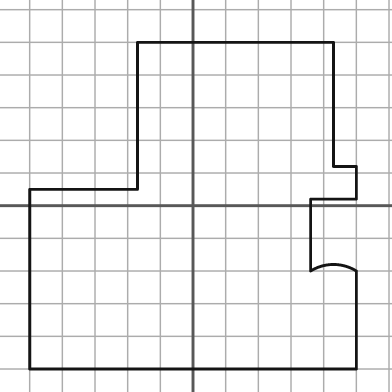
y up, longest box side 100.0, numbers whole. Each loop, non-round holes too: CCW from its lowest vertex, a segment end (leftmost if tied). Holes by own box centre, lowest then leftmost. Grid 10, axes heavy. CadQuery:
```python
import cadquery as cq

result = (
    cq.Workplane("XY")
    .moveTo(-50.0, -50.0)
    .lineTo(50.0, -50.0)
    .lineTo(50.0, -20.0)
    .threePointArc((43.0, -18.0), (36.0, -20.0))
    .lineTo(36.0, 2.0)
    .lineTo(50.0, 2.0)
    .lineTo(50.0, 12.0)
    .lineTo(43.0, 12.0)
    .lineTo(43.0, 50.0)
    .lineTo(-17.0, 50.0)
    .lineTo(-17.0, 5.0)
    .lineTo(-50.0, 5.0)
    .close()
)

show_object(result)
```